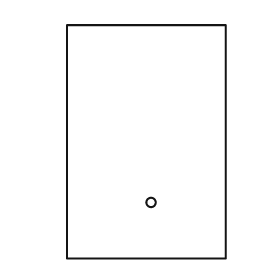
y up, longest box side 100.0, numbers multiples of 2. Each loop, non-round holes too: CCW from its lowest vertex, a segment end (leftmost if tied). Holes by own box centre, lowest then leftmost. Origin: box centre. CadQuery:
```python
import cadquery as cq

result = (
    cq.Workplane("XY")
    .moveTo(-34.0, -50.0)
    .lineTo(34.0, -50.0)
    .lineTo(34.0, 50.0)
    .lineTo(-34.0, 50.0)
    .close()
    .moveTo(2.0, -26.0)
    .circle(2.0)
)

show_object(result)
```